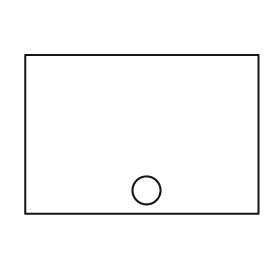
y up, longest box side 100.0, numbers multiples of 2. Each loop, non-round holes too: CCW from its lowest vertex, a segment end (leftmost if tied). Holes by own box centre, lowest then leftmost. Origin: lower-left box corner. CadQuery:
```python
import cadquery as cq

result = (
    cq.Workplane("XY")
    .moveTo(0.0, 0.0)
    .lineTo(100.0, 0.0)
    .lineTo(100.0, 68.0)
    .lineTo(0.0, 68.0)
    .close()
    .moveTo(52.0, 10.0)
    .circle(6.0)
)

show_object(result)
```